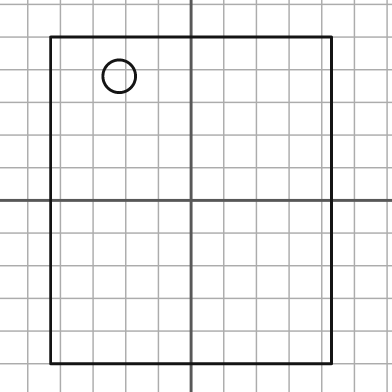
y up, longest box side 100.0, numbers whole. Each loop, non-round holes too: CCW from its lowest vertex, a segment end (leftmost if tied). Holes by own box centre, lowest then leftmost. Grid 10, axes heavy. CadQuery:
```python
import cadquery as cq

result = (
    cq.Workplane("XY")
    .moveTo(-43.0, -50.0)
    .lineTo(43.0, -50.0)
    .lineTo(43.0, 50.0)
    .lineTo(-43.0, 50.0)
    .close()
    .moveTo(-22.0, 38.0)
    .circle(5.0)
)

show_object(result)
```